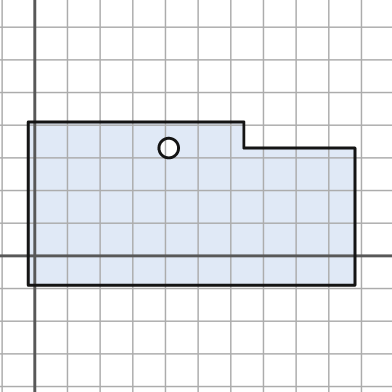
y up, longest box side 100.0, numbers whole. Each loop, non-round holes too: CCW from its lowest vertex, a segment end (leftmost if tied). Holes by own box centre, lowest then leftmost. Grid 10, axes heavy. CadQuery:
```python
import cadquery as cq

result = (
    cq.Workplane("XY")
    .moveTo(-2.0, -9.0)
    .lineTo(98.0, -9.0)
    .lineTo(98.0, 33.0)
    .lineTo(64.0, 33.0)
    .lineTo(64.0, 41.0)
    .lineTo(-2.0, 41.0)
    .close()
    .moveTo(41.0, 33.0)
    .circle(3.0)
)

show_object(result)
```